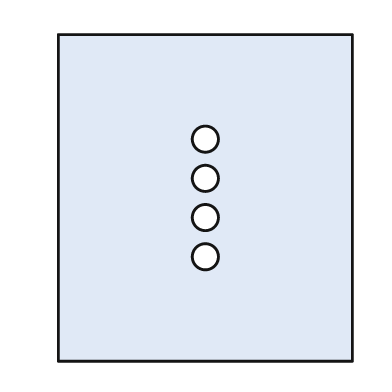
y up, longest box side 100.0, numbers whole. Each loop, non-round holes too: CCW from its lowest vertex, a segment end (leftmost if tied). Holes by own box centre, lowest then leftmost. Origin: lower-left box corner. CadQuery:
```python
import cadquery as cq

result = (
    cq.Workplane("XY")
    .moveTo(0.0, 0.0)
    .lineTo(90.0, 0.0)
    .lineTo(90.0, 100.0)
    .lineTo(0.0, 100.0)
    .close()
    .moveTo(45.0, 32.0)
    .circle(4.0)
    .moveTo(45.0, 44.0)
    .circle(4.0)
    .moveTo(45.0, 56.0)
    .circle(4.0)
    .moveTo(45.0, 68.0)
    .circle(4.0)
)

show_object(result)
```